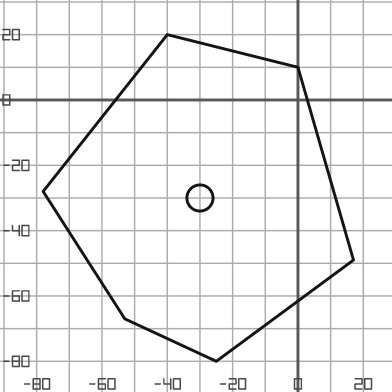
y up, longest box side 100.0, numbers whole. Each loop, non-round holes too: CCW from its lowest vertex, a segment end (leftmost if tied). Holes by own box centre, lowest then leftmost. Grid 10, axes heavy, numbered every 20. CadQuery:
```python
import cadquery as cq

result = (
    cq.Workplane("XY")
    .moveTo(-25.0, -80.0)
    .lineTo(17.0, -49.0)
    .lineTo(0.0, 10.0)
    .lineTo(-40.0, 20.0)
    .lineTo(-78.0, -28.0)
    .lineTo(-53.0, -67.0)
    .close()
    .moveTo(-30.0, -30.0)
    .circle(4.0)
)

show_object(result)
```